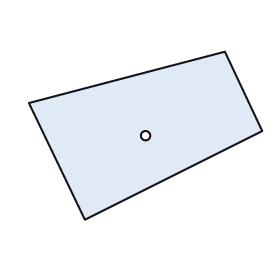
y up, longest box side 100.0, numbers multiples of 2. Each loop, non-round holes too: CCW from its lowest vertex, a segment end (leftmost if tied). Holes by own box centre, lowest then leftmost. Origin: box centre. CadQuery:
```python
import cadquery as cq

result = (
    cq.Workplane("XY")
    .moveTo(-26.0, -36.0)
    .lineTo(50.0, 2.0)
    .lineTo(34.0, 36.0)
    .lineTo(-50.0, 14.0)
    .close()
    .moveTo(0.0, 0.0)
    .circle(2.0)
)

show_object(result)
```